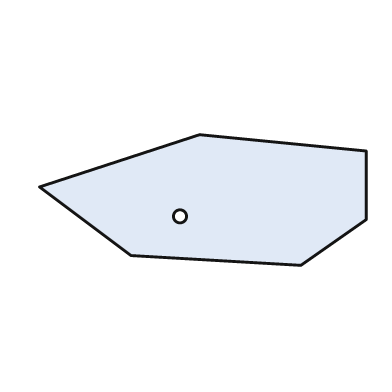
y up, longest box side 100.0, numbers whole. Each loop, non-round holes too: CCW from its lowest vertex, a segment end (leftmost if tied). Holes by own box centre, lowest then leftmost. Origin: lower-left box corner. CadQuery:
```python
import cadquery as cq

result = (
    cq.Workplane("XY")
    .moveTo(80.0, 0.0)
    .lineTo(100.0, 14.0)
    .lineTo(100.0, 35.0)
    .lineTo(49.0, 40.0)
    .lineTo(0.0, 24.0)
    .lineTo(28.0, 3.0)
    .close()
    .moveTo(43.0, 15.0)
    .circle(2.0)
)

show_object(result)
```